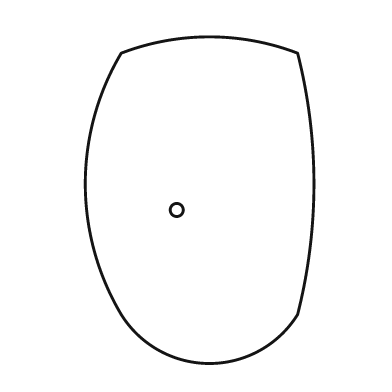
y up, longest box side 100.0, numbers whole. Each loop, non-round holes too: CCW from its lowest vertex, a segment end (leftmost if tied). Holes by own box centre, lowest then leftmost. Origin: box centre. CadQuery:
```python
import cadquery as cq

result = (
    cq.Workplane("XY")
    .moveTo(-24.0, -35.0)
    .threePointArc((3.0, -50.0), (30.0, -35.0))
    .threePointArc((35.0, 5.0), (30.0, 45.0))
    .threePointArc((3.0, 50.0), (-24.0, 45.0))
    .threePointArc((-35.0, 5.0), (-24.0, -35.0))
    .close()
    .moveTo(-7.0, -3.0)
    .circle(2.0)
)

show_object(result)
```